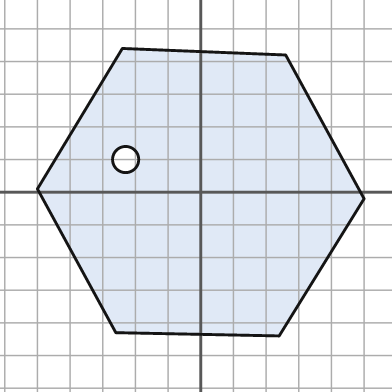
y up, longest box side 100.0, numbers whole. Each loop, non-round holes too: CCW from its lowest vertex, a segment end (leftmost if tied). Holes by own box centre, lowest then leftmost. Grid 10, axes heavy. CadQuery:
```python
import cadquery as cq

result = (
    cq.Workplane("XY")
    .moveTo(24.0, -44.0)
    .lineTo(50.0, -2.0)
    .lineTo(26.0, 42.0)
    .lineTo(-24.0, 44.0)
    .lineTo(-50.0, 1.0)
    .lineTo(-26.0, -43.0)
    .close()
    .moveTo(-23.0, 10.0)
    .circle(4.0)
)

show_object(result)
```